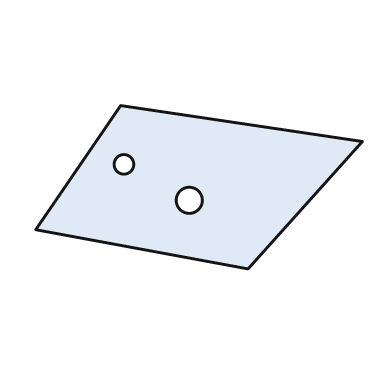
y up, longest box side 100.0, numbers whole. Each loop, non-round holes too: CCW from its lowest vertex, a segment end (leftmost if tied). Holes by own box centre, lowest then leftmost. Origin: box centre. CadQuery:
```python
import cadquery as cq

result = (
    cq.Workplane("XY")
    .moveTo(15.0, -25.0)
    .lineTo(50.0, 14.0)
    .lineTo(-24.0, 25.0)
    .lineTo(-50.0, -13.0)
    .close()
    .moveTo(-3.0, -4.0)
    .circle(4.0)
    .moveTo(-23.0, 7.0)
    .circle(3.0)
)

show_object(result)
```